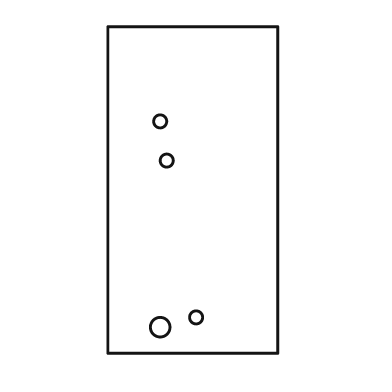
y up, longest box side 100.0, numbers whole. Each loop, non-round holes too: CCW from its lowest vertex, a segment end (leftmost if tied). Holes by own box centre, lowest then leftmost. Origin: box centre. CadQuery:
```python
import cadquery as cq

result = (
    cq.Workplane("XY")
    .moveTo(-26.0, -50.0)
    .lineTo(26.0, -50.0)
    .lineTo(26.0, 50.0)
    .lineTo(-26.0, 50.0)
    .close()
    .moveTo(-10.0, -42.0)
    .circle(3.0)
    .moveTo(1.0, -39.0)
    .circle(2.0)
    .moveTo(-8.0, 9.0)
    .circle(2.0)
    .moveTo(-10.0, 21.0)
    .circle(2.0)
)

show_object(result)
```